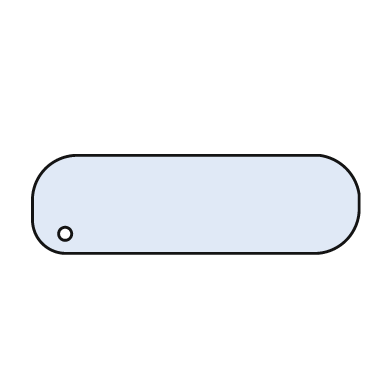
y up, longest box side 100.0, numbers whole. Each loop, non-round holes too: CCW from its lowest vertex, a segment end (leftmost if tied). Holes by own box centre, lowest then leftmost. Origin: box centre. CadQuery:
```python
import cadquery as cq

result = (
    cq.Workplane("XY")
    .moveTo(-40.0, -15.0)
    .lineTo(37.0, -15.0)
    .threePointArc((46.0, -11.0), (50.0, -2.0))
    .lineTo(50.0, 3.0)
    .threePointArc((46.0, 11.0), (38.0, 15.0))
    .lineTo(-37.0, 15.0)
    .threePointArc((-46.0, 11.0), (-50.0, 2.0))
    .lineTo(-50.0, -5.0)
    .threePointArc((-47.0, -12.0), (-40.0, -15.0))
    .close()
    .moveTo(-40.0, -9.0)
    .circle(2.0)
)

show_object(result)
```